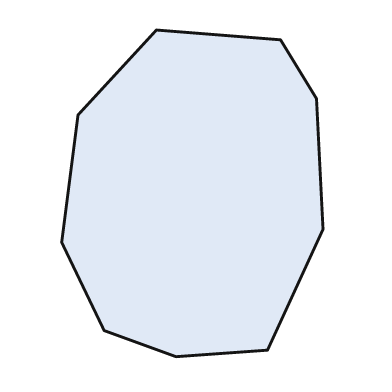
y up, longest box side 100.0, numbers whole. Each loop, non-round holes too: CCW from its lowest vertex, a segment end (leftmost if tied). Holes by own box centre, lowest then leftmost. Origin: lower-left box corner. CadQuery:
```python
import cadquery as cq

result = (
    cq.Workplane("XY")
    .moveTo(35.0, 0.0)
    .lineTo(63.0, 2.0)
    .lineTo(80.0, 39.0)
    .lineTo(78.0, 79.0)
    .lineTo(67.0, 97.0)
    .lineTo(29.0, 100.0)
    .lineTo(5.0, 74.0)
    .lineTo(0.0, 35.0)
    .lineTo(13.0, 8.0)
    .close()
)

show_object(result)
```